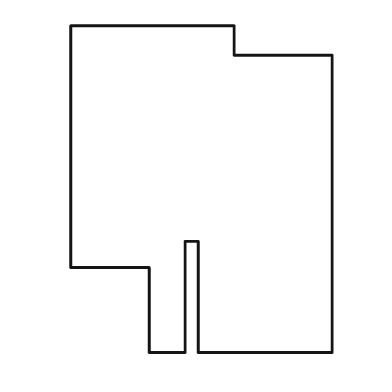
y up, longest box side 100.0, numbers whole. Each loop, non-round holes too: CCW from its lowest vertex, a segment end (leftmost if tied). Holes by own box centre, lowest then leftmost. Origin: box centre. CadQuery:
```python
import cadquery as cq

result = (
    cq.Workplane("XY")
    .moveTo(-16.0, -50.0)
    .lineTo(-5.0, -50.0)
    .lineTo(-5.0, -16.0)
    .lineTo(-1.0, -16.0)
    .lineTo(-1.0, -50.0)
    .lineTo(40.0, -50.0)
    .lineTo(40.0, 41.0)
    .lineTo(10.0, 41.0)
    .lineTo(10.0, 50.0)
    .lineTo(-40.0, 50.0)
    .lineTo(-40.0, -24.0)
    .lineTo(-16.0, -24.0)
    .close()
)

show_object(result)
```